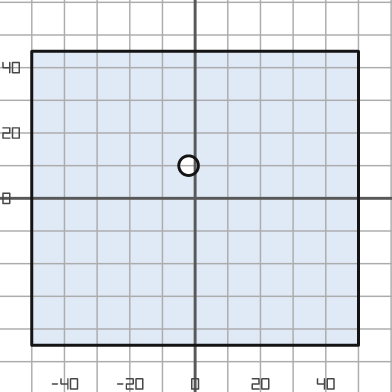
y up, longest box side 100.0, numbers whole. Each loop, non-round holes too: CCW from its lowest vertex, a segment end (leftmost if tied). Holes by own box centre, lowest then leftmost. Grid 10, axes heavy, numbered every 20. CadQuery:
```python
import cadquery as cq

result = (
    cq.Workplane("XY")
    .moveTo(-50.0, -45.0)
    .lineTo(50.0, -45.0)
    .lineTo(50.0, 45.0)
    .lineTo(-50.0, 45.0)
    .close()
    .moveTo(-2.0, 10.0)
    .circle(3.0)
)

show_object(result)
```